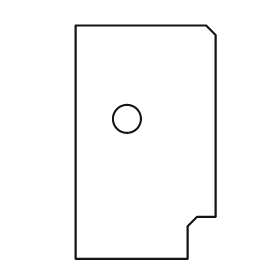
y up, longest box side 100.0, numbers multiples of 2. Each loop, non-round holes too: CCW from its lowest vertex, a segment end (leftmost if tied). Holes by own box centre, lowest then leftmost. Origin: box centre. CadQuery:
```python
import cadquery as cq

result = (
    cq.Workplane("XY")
    .moveTo(-30.0, -50.0)
    .lineTo(18.0, -50.0)
    .lineTo(18.0, -36.0)
    .lineTo(22.0, -32.0)
    .lineTo(30.0, -32.0)
    .lineTo(30.0, 46.0)
    .lineTo(26.0, 50.0)
    .lineTo(-30.0, 50.0)
    .close()
    .moveTo(-8.0, 10.0)
    .circle(6.0)
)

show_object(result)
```